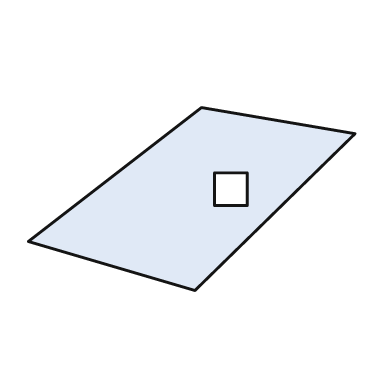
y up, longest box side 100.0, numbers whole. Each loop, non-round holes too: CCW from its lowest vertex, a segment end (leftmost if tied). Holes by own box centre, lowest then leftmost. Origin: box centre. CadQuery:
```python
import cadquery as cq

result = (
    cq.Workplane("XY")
    .moveTo(1.0, -28.0)
    .lineTo(50.0, 20.0)
    .lineTo(3.0, 28.0)
    .lineTo(-50.0, -13.0)
    .close()
    .moveTo(7.0, -2.0)
    .lineTo(17.0, -2.0)
    .lineTo(17.0, 8.0)
    .lineTo(7.0, 8.0)
    .close()
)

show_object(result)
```